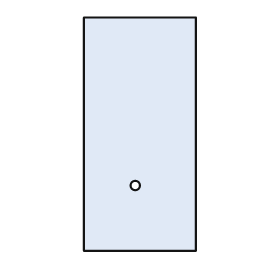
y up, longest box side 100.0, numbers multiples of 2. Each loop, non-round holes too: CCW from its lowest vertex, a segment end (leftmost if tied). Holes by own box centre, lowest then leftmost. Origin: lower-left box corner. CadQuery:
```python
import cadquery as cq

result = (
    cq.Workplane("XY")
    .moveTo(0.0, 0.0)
    .lineTo(48.0, 0.0)
    .lineTo(48.0, 100.0)
    .lineTo(0.0, 100.0)
    .close()
    .moveTo(22.0, 28.0)
    .circle(2.0)
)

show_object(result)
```